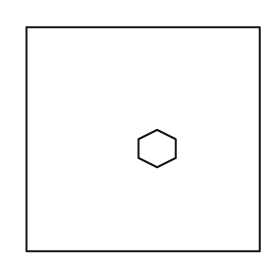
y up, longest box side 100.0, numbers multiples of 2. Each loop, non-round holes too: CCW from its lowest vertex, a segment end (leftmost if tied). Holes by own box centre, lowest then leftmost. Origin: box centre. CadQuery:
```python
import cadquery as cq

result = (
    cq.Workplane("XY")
    .moveTo(-50.0, -48.0)
    .lineTo(50.0, -48.0)
    .lineTo(50.0, 48.0)
    .lineTo(-50.0, 48.0)
    .close()
    .moveTo(6.0, -12.0)
    .lineTo(14.0, -8.0)
    .lineTo(14.0, 0.0)
    .lineTo(6.0, 4.0)
    .lineTo(-2.0, 0.0)
    .lineTo(-2.0, -8.0)
    .close()
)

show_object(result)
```